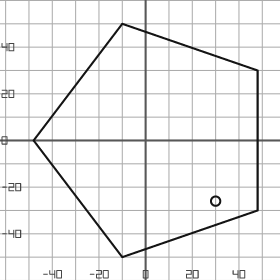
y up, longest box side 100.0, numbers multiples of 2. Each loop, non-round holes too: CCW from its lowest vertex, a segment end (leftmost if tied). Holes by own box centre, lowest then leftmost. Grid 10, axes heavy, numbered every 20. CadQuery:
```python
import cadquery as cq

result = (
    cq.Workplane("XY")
    .moveTo(-10.0, -50.0)
    .lineTo(48.0, -30.0)
    .lineTo(48.0, 30.0)
    .lineTo(-10.0, 50.0)
    .lineTo(-48.0, 0.0)
    .close()
    .moveTo(30.0, -26.0)
    .circle(2.0)
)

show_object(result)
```